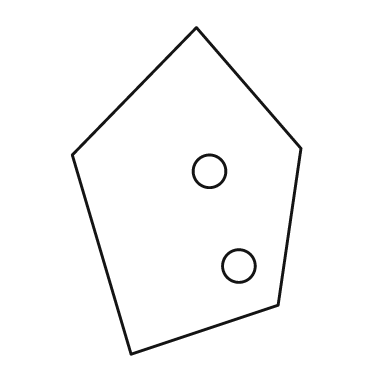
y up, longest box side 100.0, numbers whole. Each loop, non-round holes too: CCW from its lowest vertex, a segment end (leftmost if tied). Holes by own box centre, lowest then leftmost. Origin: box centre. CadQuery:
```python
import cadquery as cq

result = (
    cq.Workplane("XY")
    .moveTo(-17.0, -50.0)
    .lineTo(28.0, -35.0)
    .lineTo(35.0, 13.0)
    .lineTo(3.0, 50.0)
    .lineTo(-35.0, 11.0)
    .close()
    .moveTo(16.0, -23.0)
    .circle(5.0)
    .moveTo(7.0, 6.0)
    .circle(5.0)
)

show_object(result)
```